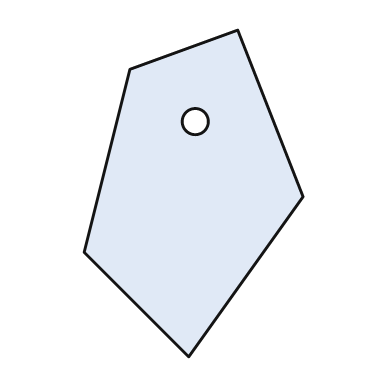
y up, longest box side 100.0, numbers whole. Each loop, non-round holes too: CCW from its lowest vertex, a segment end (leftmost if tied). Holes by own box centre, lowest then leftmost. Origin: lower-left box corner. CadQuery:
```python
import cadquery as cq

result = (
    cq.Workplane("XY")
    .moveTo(32.0, 0.0)
    .lineTo(67.0, 49.0)
    .lineTo(47.0, 100.0)
    .lineTo(14.0, 88.0)
    .lineTo(0.0, 32.0)
    .close()
    .moveTo(34.0, 72.0)
    .circle(4.0)
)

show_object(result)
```